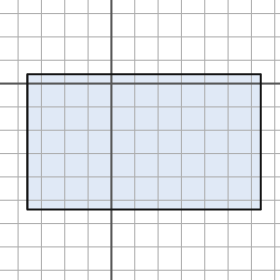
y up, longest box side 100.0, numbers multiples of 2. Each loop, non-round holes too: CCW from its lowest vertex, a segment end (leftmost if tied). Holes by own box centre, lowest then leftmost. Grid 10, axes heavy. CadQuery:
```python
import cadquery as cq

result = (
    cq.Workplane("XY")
    .moveTo(-36.0, -54.0)
    .lineTo(64.0, -54.0)
    .lineTo(64.0, 4.0)
    .lineTo(-36.0, 4.0)
    .close()
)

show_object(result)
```